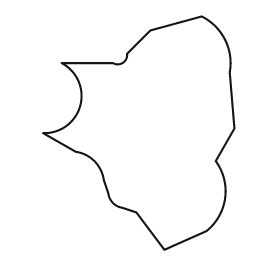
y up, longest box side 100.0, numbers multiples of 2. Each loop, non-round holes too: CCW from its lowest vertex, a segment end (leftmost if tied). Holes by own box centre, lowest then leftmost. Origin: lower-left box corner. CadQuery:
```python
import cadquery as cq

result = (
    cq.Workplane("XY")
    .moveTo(52.0, 0.0)
    .lineTo(70.0, 8.0)
    .threePointArc((78.0, 22.0), (74.0, 38.0))
    .lineTo(82.0, 52.0)
    .lineTo(80.0, 76.0)
    .threePointArc((78.0, 90.0), (68.0, 100.0))
    .lineTo(46.0, 94.0)
    .lineTo(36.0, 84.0)
    .threePointArc((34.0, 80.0), (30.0, 80.0))
    .lineTo(8.0, 80.0)
    .threePointArc((16.0, 62.0), (0.0, 50.0))
    .lineTo(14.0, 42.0)
    .threePointArc((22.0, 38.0), (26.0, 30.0))
    .lineTo(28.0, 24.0)
    .threePointArc((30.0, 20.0), (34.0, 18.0))
    .lineTo(40.0, 16.0)
    .close()
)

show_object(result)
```